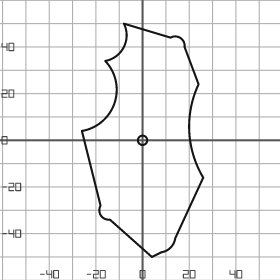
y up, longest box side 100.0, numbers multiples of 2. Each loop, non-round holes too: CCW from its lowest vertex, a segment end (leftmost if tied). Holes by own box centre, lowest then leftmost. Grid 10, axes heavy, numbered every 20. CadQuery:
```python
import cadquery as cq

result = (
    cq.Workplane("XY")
    .moveTo(4.0, -50.0)
    .lineTo(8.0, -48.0)
    .threePointArc((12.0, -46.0), (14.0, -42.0))
    .lineTo(26.0, -16.0)
    .threePointArc((20.0, 4.0), (24.0, 24.0))
    .lineTo(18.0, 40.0)
    .threePointArc((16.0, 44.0), (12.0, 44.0))
    .lineTo(-8.0, 50.0)
    .threePointArc((-8.0, 40.0), (-16.0, 34.0))
    .threePointArc((-12.0, 16.0), (-26.0, 4.0))
    .lineTo(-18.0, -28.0)
    .threePointArc((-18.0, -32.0), (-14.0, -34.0))
    .close()
    .moveTo(0.0, 0.0)
    .circle(2.0)
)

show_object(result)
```